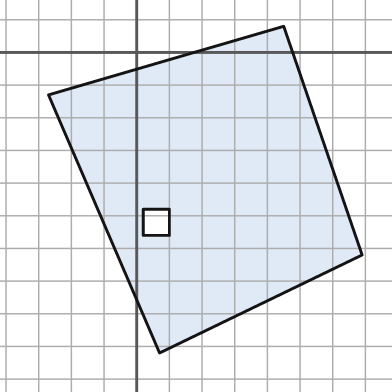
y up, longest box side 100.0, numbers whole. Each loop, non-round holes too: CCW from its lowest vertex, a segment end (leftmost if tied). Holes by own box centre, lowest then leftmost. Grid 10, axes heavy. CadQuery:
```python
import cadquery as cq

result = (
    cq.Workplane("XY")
    .moveTo(7.0, -92.0)
    .lineTo(69.0, -62.0)
    .lineTo(45.0, 8.0)
    .lineTo(-27.0, -13.0)
    .close()
    .moveTo(2.0, -56.0)
    .lineTo(10.0, -56.0)
    .lineTo(10.0, -48.0)
    .lineTo(2.0, -48.0)
    .close()
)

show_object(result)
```